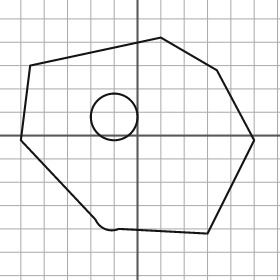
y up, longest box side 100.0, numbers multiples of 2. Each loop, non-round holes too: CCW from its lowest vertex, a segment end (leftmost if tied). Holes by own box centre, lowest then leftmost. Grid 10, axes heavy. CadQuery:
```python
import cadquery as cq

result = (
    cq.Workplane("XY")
    .moveTo(30.0, -42.0)
    .lineTo(50.0, -2.0)
    .lineTo(34.0, 28.0)
    .lineTo(10.0, 42.0)
    .lineTo(-46.0, 30.0)
    .lineTo(-50.0, -2.0)
    .lineTo(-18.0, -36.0)
    .threePointArc((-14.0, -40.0), (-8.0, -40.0))
    .close()
    .moveTo(-10.0, 8.0)
    .circle(10.0)
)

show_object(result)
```